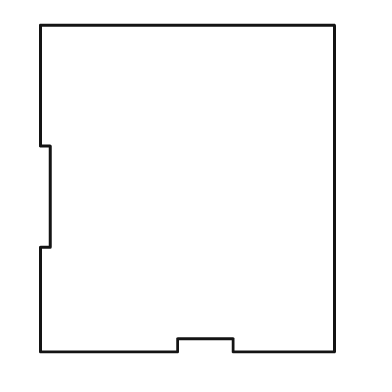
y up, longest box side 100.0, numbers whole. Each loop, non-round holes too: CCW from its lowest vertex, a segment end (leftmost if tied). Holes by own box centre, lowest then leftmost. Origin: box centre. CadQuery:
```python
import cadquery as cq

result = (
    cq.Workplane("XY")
    .moveTo(-45.0, -50.0)
    .lineTo(-3.0, -50.0)
    .lineTo(-3.0, -46.0)
    .lineTo(14.0, -46.0)
    .lineTo(14.0, -50.0)
    .lineTo(45.0, -50.0)
    .lineTo(45.0, 50.0)
    .lineTo(-45.0, 50.0)
    .lineTo(-45.0, 13.0)
    .lineTo(-42.0, 13.0)
    .lineTo(-42.0, -18.0)
    .lineTo(-45.0, -18.0)
    .close()
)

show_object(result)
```